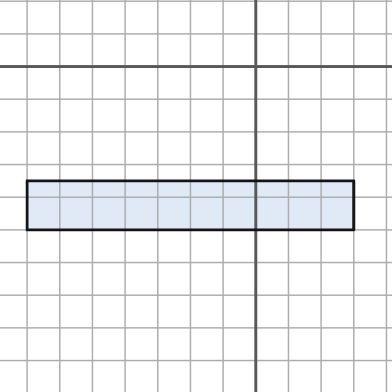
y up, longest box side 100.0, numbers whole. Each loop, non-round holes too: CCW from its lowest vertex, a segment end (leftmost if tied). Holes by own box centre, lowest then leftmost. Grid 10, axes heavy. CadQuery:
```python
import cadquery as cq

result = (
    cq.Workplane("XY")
    .moveTo(-70.0, -50.0)
    .lineTo(30.0, -50.0)
    .lineTo(30.0, -35.0)
    .lineTo(-70.0, -35.0)
    .close()
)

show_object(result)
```